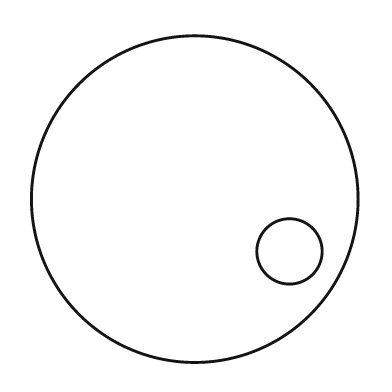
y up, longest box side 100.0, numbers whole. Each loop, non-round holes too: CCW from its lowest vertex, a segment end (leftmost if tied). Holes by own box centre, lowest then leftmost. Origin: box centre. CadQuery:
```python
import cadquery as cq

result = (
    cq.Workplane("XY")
    .moveTo(0.0, 0.0)
    .circle(50.0)
    .moveTo(29.0, -16.0)
    .circle(10.0)
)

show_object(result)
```